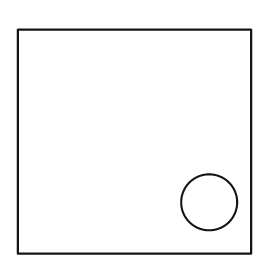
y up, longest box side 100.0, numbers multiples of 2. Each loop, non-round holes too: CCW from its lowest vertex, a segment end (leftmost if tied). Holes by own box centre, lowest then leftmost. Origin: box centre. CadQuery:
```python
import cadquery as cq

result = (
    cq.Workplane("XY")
    .moveTo(-50.0, -48.0)
    .lineTo(50.0, -48.0)
    .lineTo(50.0, 48.0)
    .lineTo(-50.0, 48.0)
    .close()
    .moveTo(32.0, -26.0)
    .circle(12.0)
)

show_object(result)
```